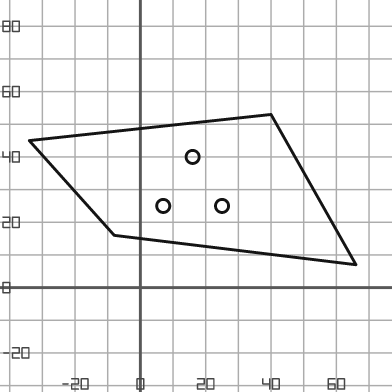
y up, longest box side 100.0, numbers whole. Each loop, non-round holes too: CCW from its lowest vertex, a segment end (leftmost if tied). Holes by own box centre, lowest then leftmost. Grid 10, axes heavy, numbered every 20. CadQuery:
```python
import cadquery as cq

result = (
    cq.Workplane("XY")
    .moveTo(66.0, 7.0)
    .lineTo(40.0, 53.0)
    .lineTo(-34.0, 45.0)
    .lineTo(-8.0, 16.0)
    .close()
    .moveTo(7.0, 25.0)
    .circle(2.0)
    .moveTo(25.0, 25.0)
    .circle(2.0)
    .moveTo(16.0, 40.0)
    .circle(2.0)
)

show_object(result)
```